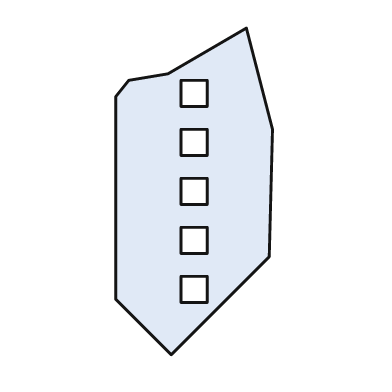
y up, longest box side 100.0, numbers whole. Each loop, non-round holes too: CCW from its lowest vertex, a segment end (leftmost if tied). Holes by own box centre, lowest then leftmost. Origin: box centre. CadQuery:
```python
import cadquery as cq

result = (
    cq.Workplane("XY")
    .moveTo(-7.0, -50.0)
    .lineTo(23.0, -20.0)
    .lineTo(24.0, 19.0)
    .lineTo(16.0, 50.0)
    .lineTo(-8.0, 36.0)
    .lineTo(-20.0, 34.0)
    .lineTo(-24.0, 29.0)
    .lineTo(-24.0, -33.0)
    .close()
    .moveTo(-4.0, -34.0)
    .lineTo(4.0, -34.0)
    .lineTo(4.0, -26.0)
    .lineTo(-4.0, -26.0)
    .close()
    .moveTo(-4.0, -19.0)
    .lineTo(4.0, -19.0)
    .lineTo(4.0, -11.0)
    .lineTo(-4.0, -11.0)
    .close()
    .moveTo(-4.0, -4.0)
    .lineTo(4.0, -4.0)
    .lineTo(4.0, 4.0)
    .lineTo(-4.0, 4.0)
    .close()
    .moveTo(-4.0, 11.0)
    .lineTo(4.0, 11.0)
    .lineTo(4.0, 19.0)
    .lineTo(-4.0, 19.0)
    .close()
    .moveTo(-4.0, 26.0)
    .lineTo(4.0, 26.0)
    .lineTo(4.0, 34.0)
    .lineTo(-4.0, 34.0)
    .close()
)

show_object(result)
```